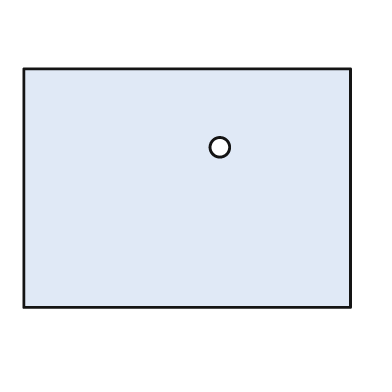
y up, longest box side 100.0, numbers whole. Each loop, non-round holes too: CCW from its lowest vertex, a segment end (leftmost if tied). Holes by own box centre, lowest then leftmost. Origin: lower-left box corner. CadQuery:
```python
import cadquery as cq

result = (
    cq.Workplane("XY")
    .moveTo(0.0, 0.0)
    .lineTo(100.0, 0.0)
    .lineTo(100.0, 73.0)
    .lineTo(0.0, 73.0)
    .close()
    .moveTo(60.0, 49.0)
    .circle(3.0)
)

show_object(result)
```